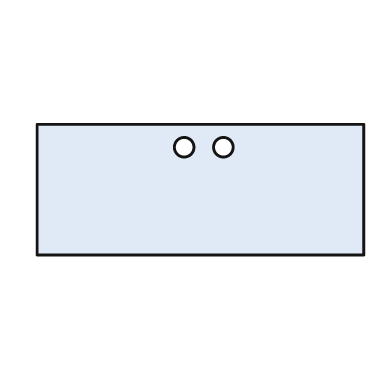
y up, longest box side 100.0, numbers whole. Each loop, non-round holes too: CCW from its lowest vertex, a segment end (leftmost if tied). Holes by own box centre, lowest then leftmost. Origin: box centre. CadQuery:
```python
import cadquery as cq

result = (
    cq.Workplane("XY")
    .moveTo(-50.0, -20.0)
    .lineTo(50.0, -20.0)
    .lineTo(50.0, 20.0)
    .lineTo(-50.0, 20.0)
    .close()
    .moveTo(-5.0, 13.0)
    .circle(3.0)
    .moveTo(7.0, 13.0)
    .circle(3.0)
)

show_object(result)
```